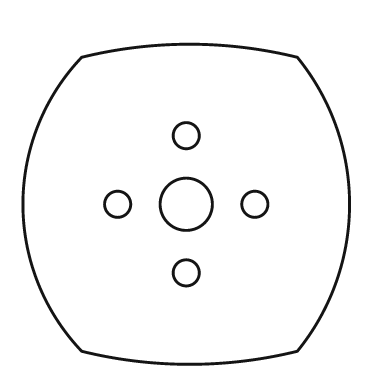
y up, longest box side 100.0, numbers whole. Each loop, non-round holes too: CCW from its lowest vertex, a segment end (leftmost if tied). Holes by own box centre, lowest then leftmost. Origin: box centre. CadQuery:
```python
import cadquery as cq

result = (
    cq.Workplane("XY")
    .moveTo(-32.0, -45.0)
    .threePointArc((1.0, -49.0), (34.0, -45.0))
    .threePointArc((50.0, 0.0), (34.0, 45.0))
    .threePointArc((1.0, 49.0), (-32.0, 45.0))
    .threePointArc((-50.0, 0.0), (-32.0, -45.0))
    .close()
    .moveTo(0.0, -21.0)
    .circle(4.0)
    .moveTo(-21.0, 0.0)
    .circle(4.0)
    .moveTo(0.0, 0.0)
    .circle(8.0)
    .moveTo(21.0, 0.0)
    .circle(4.0)
    .moveTo(0.0, 21.0)
    .circle(4.0)
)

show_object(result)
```